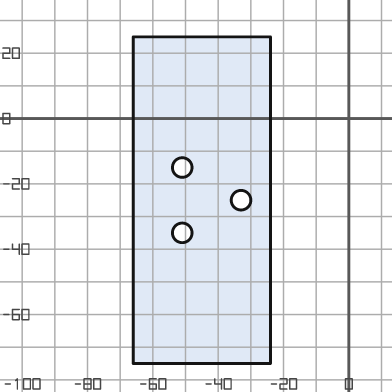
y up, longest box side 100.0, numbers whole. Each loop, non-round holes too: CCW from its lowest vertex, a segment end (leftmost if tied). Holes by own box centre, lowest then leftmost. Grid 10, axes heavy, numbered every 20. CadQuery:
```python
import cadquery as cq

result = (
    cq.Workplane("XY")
    .moveTo(-66.0, -75.0)
    .lineTo(-24.0, -75.0)
    .lineTo(-24.0, 25.0)
    .lineTo(-66.0, 25.0)
    .close()
    .moveTo(-51.0, -35.0)
    .circle(3.0)
    .moveTo(-33.0, -25.0)
    .circle(3.0)
    .moveTo(-51.0, -15.0)
    .circle(3.0)
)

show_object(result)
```